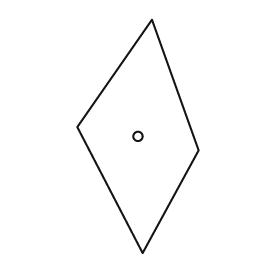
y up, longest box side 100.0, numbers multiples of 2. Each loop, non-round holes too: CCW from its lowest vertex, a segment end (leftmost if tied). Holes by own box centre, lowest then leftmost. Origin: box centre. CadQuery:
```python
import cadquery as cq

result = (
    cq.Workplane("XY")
    .moveTo(2.0, -50.0)
    .lineTo(26.0, -6.0)
    .lineTo(6.0, 50.0)
    .lineTo(-26.0, 4.0)
    .close()
    .moveTo(0.0, 0.0)
    .circle(2.0)
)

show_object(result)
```